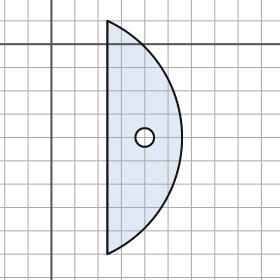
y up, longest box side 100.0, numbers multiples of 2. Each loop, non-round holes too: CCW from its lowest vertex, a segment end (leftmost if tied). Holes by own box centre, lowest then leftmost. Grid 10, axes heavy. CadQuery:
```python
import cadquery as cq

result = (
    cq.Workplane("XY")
    .moveTo(24.0, -90.0)
    .threePointArc((56.0, -40.0), (24.0, 10.0))
    .close()
    .moveTo(40.0, -40.0)
    .circle(4.0)
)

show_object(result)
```